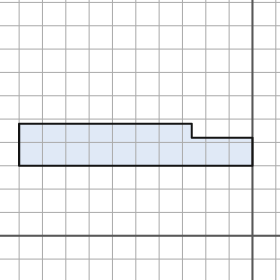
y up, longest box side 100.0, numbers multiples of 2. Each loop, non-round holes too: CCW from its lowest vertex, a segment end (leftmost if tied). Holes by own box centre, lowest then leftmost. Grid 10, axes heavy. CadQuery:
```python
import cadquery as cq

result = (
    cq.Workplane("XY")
    .moveTo(-100.0, 30.0)
    .lineTo(0.0, 30.0)
    .lineTo(0.0, 42.0)
    .lineTo(-26.0, 42.0)
    .lineTo(-26.0, 48.0)
    .lineTo(-100.0, 48.0)
    .close()
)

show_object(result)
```